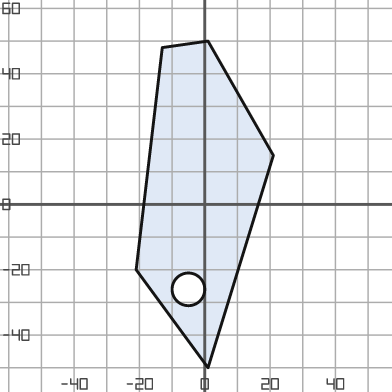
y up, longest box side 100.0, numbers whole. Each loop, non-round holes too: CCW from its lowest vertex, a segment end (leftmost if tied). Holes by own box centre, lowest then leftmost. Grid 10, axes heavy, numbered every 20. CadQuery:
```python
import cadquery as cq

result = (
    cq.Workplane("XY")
    .moveTo(1.0, -50.0)
    .lineTo(21.0, 15.0)
    .lineTo(1.0, 50.0)
    .lineTo(-13.0, 48.0)
    .lineTo(-21.0, -20.0)
    .close()
    .moveTo(-5.0, -26.0)
    .circle(5.0)
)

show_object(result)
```